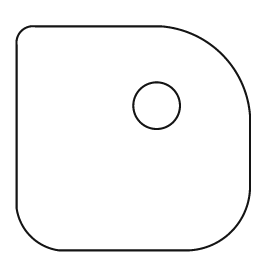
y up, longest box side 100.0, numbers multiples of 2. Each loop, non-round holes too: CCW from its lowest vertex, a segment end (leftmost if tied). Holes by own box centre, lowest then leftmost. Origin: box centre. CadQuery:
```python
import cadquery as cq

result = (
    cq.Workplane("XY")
    .moveTo(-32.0, -48.0)
    .lineTo(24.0, -48.0)
    .threePointArc((42.0, -40.0), (50.0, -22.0))
    .lineTo(50.0, 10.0)
    .threePointArc((38.0, 36.0), (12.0, 48.0))
    .lineTo(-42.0, 48.0)
    .threePointArc((-48.0, 46.0), (-50.0, 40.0))
    .lineTo(-50.0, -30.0)
    .threePointArc((-44.0, -42.0), (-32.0, -48.0))
    .close()
    .moveTo(10.0, 14.0)
    .circle(10.0)
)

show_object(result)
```